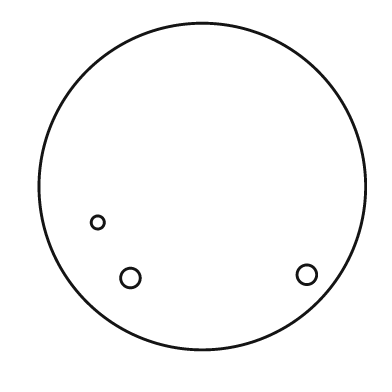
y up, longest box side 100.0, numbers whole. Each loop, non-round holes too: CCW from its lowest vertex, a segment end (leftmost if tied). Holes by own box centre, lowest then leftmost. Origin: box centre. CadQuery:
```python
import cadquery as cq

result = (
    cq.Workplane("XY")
    .moveTo(0.0, 0.0)
    .circle(50.0)
    .moveTo(-22.0, -28.0)
    .circle(3.0)
    .moveTo(32.0, -27.0)
    .circle(3.0)
    .moveTo(-32.0, -11.0)
    .circle(2.0)
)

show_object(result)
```